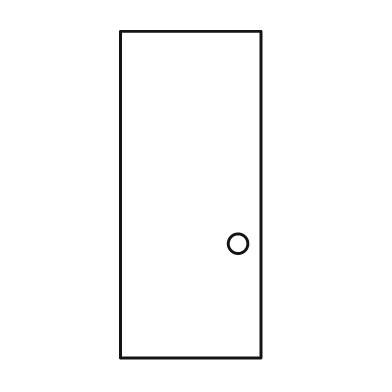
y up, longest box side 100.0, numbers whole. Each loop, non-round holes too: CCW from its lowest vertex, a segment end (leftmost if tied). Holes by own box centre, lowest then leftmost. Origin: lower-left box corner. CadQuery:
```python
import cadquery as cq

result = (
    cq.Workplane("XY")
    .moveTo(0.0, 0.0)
    .lineTo(43.0, 0.0)
    .lineTo(43.0, 100.0)
    .lineTo(0.0, 100.0)
    .close()
    .moveTo(36.0, 35.0)
    .circle(3.0)
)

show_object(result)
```